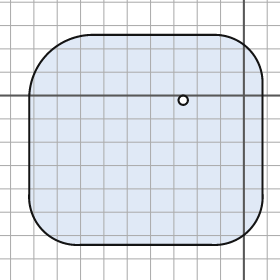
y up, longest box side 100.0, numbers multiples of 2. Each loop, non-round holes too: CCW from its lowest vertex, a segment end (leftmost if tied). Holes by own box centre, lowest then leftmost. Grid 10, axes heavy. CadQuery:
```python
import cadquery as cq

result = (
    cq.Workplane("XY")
    .moveTo(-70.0, -64.0)
    .lineTo(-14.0, -64.0)
    .threePointArc((2.0, -58.0), (8.0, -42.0))
    .lineTo(8.0, 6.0)
    .threePointArc((2.0, 20.0), (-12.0, 26.0))
    .lineTo(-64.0, 26.0)
    .threePointArc((-84.0, 18.0), (-92.0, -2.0))
    .lineTo(-92.0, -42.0)
    .threePointArc((-86.0, -58.0), (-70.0, -64.0))
    .close()
    .moveTo(-26.0, -2.0)
    .circle(2.0)
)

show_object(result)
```